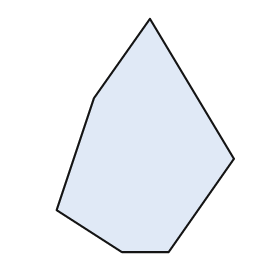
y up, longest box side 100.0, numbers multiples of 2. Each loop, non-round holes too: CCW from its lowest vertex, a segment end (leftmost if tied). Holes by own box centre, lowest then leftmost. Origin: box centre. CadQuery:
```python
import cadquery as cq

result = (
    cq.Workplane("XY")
    .moveTo(-10.0, -50.0)
    .lineTo(10.0, -50.0)
    .lineTo(38.0, -10.0)
    .lineTo(2.0, 50.0)
    .lineTo(-22.0, 16.0)
    .lineTo(-38.0, -32.0)
    .close()
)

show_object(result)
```